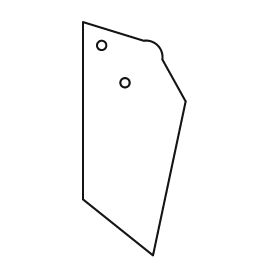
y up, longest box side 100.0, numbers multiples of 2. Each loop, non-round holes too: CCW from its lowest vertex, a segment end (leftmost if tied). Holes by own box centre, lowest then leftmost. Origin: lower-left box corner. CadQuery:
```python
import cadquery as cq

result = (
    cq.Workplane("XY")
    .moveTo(30.0, 0.0)
    .lineTo(44.0, 66.0)
    .lineTo(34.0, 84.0)
    .threePointArc((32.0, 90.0), (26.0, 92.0))
    .lineTo(0.0, 100.0)
    .lineTo(0.0, 24.0)
    .close()
    .moveTo(18.0, 74.0)
    .circle(2.0)
    .moveTo(8.0, 90.0)
    .circle(2.0)
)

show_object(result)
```